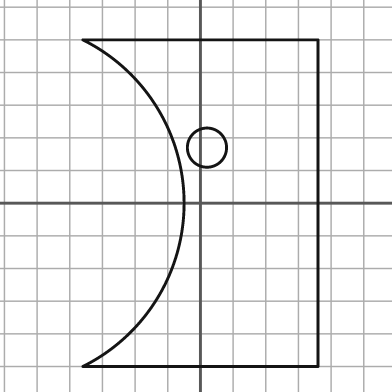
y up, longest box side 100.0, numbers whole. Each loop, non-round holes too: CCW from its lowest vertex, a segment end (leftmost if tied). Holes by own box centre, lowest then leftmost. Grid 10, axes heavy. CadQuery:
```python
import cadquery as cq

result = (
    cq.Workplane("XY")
    .moveTo(-36.0, -50.0)
    .lineTo(36.0, -50.0)
    .lineTo(36.0, 50.0)
    .lineTo(-36.0, 50.0)
    .threePointArc((-5.0, 0.0), (-36.0, -50.0))
    .close()
    .moveTo(2.0, 17.0)
    .circle(6.0)
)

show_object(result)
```